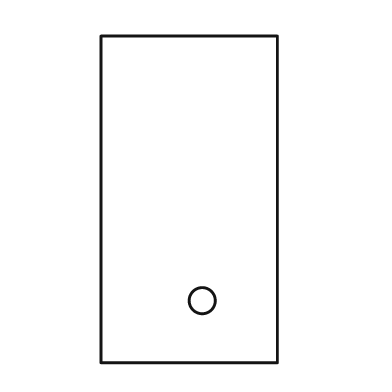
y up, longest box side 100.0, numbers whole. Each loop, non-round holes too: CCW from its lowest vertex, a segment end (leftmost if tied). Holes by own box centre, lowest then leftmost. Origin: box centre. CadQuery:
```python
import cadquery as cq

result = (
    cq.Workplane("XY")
    .moveTo(-27.0, -50.0)
    .lineTo(27.0, -50.0)
    .lineTo(27.0, 50.0)
    .lineTo(-27.0, 50.0)
    .close()
    .moveTo(4.0, -31.0)
    .circle(4.0)
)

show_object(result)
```